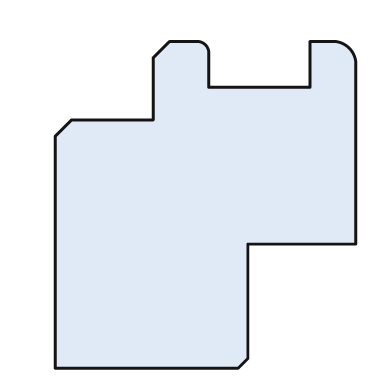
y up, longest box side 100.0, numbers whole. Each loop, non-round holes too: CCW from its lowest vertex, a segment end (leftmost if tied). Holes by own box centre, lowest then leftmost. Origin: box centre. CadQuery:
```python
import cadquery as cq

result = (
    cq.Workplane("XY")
    .moveTo(-46.0, -50.0)
    .lineTo(10.0, -50.0)
    .lineTo(13.0, -47.0)
    .lineTo(13.0, -12.0)
    .lineTo(46.0, -12.0)
    .lineTo(46.0, 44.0)
    .threePointArc((44.0, 48.0), (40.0, 50.0))
    .lineTo(32.0, 50.0)
    .lineTo(32.0, 36.0)
    .lineTo(1.0, 36.0)
    .lineTo(1.0, 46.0)
    .threePointArc((0.0, 49.0), (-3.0, 50.0))
    .lineTo(-11.0, 50.0)
    .lineTo(-16.0, 45.0)
    .lineTo(-16.0, 26.0)
    .lineTo(-41.0, 26.0)
    .lineTo(-46.0, 21.0)
    .close()
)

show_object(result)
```